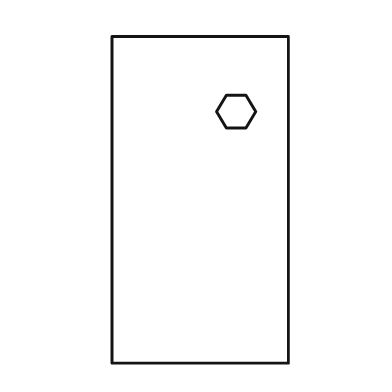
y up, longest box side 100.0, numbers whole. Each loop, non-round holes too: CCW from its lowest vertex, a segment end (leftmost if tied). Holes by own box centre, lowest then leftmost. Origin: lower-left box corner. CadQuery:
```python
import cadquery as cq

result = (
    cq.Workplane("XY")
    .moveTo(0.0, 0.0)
    .lineTo(54.0, 0.0)
    .lineTo(54.0, 100.0)
    .lineTo(0.0, 100.0)
    .close()
    .moveTo(35.0, 72.0)
    .lineTo(41.0, 72.0)
    .lineTo(44.0, 77.0)
    .lineTo(41.0, 82.0)
    .lineTo(35.0, 82.0)
    .lineTo(32.0, 77.0)
    .close()
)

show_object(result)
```